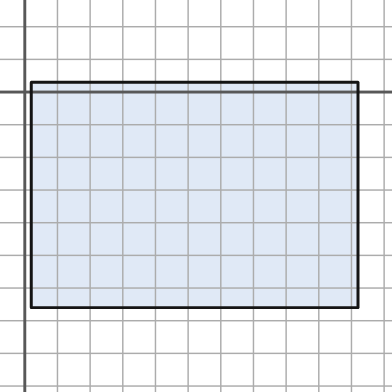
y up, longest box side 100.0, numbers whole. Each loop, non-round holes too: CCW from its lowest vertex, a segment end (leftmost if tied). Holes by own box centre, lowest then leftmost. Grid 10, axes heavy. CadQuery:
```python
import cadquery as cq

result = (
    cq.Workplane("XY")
    .moveTo(2.0, -66.0)
    .lineTo(102.0, -66.0)
    .lineTo(102.0, 3.0)
    .lineTo(2.0, 3.0)
    .close()
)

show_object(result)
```